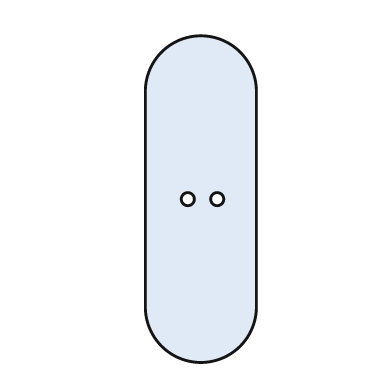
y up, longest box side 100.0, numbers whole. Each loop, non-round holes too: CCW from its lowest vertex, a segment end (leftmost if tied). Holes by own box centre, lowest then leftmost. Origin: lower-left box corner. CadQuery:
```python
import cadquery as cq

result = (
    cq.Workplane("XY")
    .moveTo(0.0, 17.0)
    .threePointArc((17.0, 0.0), (34.0, 17.0))
    .lineTo(34.0, 83.0)
    .threePointArc((17.0, 100.0), (0.0, 83.0))
    .close()
    .moveTo(13.0, 50.0)
    .circle(2.0)
    .moveTo(22.0, 50.0)
    .circle(2.0)
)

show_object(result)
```